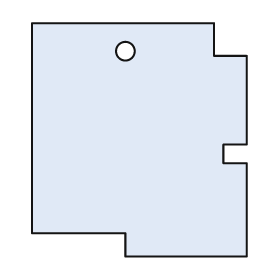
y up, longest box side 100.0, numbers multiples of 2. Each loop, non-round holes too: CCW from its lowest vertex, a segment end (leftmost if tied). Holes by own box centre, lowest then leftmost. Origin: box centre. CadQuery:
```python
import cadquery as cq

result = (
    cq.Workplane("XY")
    .moveTo(-6.0, -50.0)
    .lineTo(46.0, -50.0)
    .lineTo(46.0, -10.0)
    .lineTo(36.0, -10.0)
    .lineTo(36.0, -2.0)
    .lineTo(46.0, -2.0)
    .lineTo(46.0, 36.0)
    .lineTo(32.0, 36.0)
    .lineTo(32.0, 50.0)
    .lineTo(-46.0, 50.0)
    .lineTo(-46.0, -40.0)
    .lineTo(-6.0, -40.0)
    .close()
    .moveTo(-6.0, 38.0)
    .circle(4.0)
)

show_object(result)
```